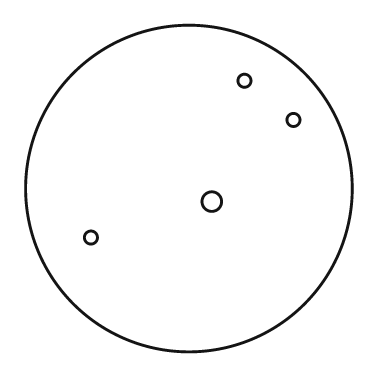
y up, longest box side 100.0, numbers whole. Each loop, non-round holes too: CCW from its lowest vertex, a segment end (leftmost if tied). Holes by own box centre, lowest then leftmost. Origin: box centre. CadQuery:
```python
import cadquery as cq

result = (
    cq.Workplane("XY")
    .moveTo(0.0, 0.0)
    .circle(50.0)
    .moveTo(-30.0, -15.0)
    .circle(2.0)
    .moveTo(7.0, -4.0)
    .circle(3.0)
    .moveTo(32.0, 21.0)
    .circle(2.0)
    .moveTo(17.0, 33.0)
    .circle(2.0)
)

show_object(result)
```